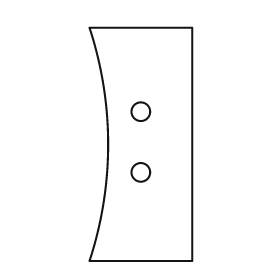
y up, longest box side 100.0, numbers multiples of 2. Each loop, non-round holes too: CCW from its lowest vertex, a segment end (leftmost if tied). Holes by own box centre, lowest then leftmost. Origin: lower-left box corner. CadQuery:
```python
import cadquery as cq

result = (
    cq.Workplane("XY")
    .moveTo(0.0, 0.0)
    .lineTo(44.0, 0.0)
    .lineTo(44.0, 100.0)
    .lineTo(0.0, 100.0)
    .threePointArc((8.0, 50.0), (0.0, 0.0))
    .close()
    .moveTo(22.0, 38.0)
    .circle(4.0)
    .moveTo(22.0, 64.0)
    .circle(4.0)
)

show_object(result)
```